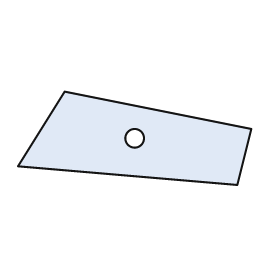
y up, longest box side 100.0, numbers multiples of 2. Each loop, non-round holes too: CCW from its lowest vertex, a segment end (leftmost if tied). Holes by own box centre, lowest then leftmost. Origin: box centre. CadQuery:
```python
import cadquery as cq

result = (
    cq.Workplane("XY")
    .moveTo(44.0, -20.0)
    .lineTo(50.0, 4.0)
    .lineTo(-30.0, 20.0)
    .lineTo(-50.0, -12.0)
    .close()
    .moveTo(0.0, 0.0)
    .circle(4.0)
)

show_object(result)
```